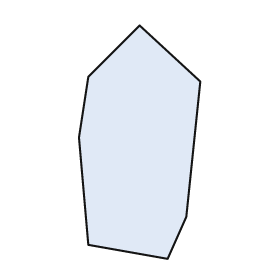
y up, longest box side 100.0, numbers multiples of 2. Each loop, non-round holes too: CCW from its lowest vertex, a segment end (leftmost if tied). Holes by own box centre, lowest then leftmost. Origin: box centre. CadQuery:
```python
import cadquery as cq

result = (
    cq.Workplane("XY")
    .moveTo(12.0, -50.0)
    .lineTo(20.0, -32.0)
    .lineTo(26.0, 26.0)
    .lineTo(0.0, 50.0)
    .lineTo(-22.0, 28.0)
    .lineTo(-26.0, 2.0)
    .lineTo(-22.0, -44.0)
    .close()
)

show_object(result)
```